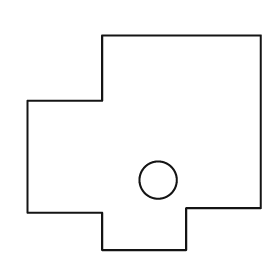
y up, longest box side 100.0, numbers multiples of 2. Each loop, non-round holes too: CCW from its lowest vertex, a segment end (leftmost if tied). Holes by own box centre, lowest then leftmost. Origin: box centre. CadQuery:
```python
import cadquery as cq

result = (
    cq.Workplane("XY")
    .moveTo(-18.0, -46.0)
    .lineTo(18.0, -46.0)
    .lineTo(18.0, -28.0)
    .lineTo(50.0, -28.0)
    .lineTo(50.0, 46.0)
    .lineTo(-18.0, 46.0)
    .lineTo(-18.0, 18.0)
    .lineTo(-50.0, 18.0)
    .lineTo(-50.0, -30.0)
    .lineTo(-18.0, -30.0)
    .close()
    .moveTo(6.0, -16.0)
    .circle(8.0)
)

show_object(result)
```